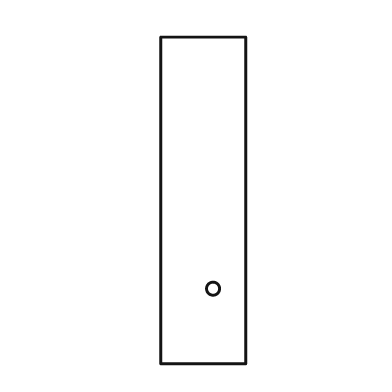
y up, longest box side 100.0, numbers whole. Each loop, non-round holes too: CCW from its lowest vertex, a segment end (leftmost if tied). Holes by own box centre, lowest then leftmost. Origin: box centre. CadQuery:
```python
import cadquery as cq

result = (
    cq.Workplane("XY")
    .moveTo(-13.0, -50.0)
    .lineTo(13.0, -50.0)
    .lineTo(13.0, 50.0)
    .lineTo(-13.0, 50.0)
    .close()
    .moveTo(3.0, -27.0)
    .circle(2.0)
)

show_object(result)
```